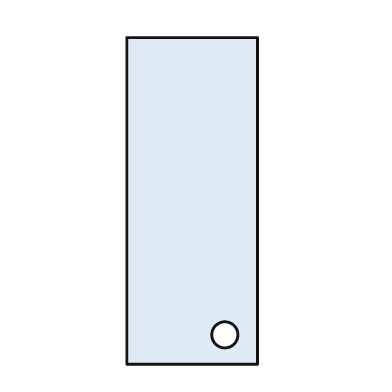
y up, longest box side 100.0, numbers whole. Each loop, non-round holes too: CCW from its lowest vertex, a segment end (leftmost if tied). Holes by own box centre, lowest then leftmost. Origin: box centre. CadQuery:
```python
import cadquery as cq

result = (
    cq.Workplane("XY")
    .moveTo(-20.0, -50.0)
    .lineTo(20.0, -50.0)
    .lineTo(20.0, 50.0)
    .lineTo(-20.0, 50.0)
    .close()
    .moveTo(10.0, -41.0)
    .circle(4.0)
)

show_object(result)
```